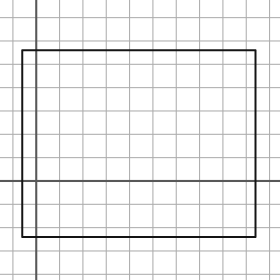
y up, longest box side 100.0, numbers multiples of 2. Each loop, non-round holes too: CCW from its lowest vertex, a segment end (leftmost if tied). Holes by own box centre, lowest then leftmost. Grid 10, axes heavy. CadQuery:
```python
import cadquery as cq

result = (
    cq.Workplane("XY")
    .moveTo(-6.0, -24.0)
    .lineTo(94.0, -24.0)
    .lineTo(94.0, 56.0)
    .lineTo(-6.0, 56.0)
    .close()
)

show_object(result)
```